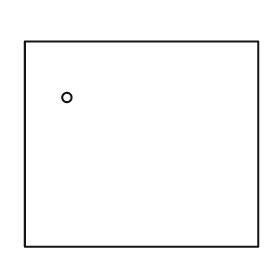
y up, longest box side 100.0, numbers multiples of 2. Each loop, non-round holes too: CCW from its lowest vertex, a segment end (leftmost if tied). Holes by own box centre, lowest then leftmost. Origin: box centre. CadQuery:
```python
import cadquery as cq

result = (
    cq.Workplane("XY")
    .moveTo(-50.0, -44.0)
    .lineTo(50.0, -44.0)
    .lineTo(50.0, 44.0)
    .lineTo(-50.0, 44.0)
    .close()
    .moveTo(-32.0, 20.0)
    .circle(2.0)
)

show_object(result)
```